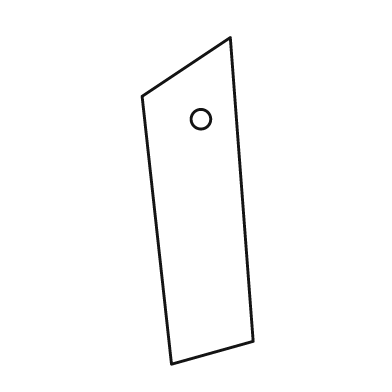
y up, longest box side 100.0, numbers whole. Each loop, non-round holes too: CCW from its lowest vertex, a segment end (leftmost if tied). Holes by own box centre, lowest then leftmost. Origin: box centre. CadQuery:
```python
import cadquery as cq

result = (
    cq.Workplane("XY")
    .moveTo(-8.0, -50.0)
    .lineTo(17.0, -43.0)
    .lineTo(10.0, 50.0)
    .lineTo(-17.0, 32.0)
    .close()
    .moveTo(1.0, 25.0)
    .circle(3.0)
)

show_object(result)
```